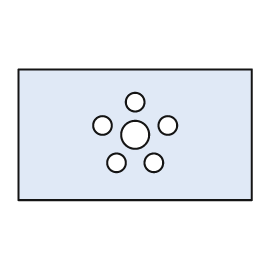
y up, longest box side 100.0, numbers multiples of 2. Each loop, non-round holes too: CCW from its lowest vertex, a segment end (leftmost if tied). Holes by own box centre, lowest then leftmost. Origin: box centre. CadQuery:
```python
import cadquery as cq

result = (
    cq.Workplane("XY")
    .moveTo(-50.0, -28.0)
    .lineTo(50.0, -28.0)
    .lineTo(50.0, 28.0)
    .lineTo(-50.0, 28.0)
    .close()
    .moveTo(-8.0, -12.0)
    .circle(4.0)
    .moveTo(8.0, -12.0)
    .circle(4.0)
    .moveTo(0.0, 0.0)
    .circle(6.0)
    .moveTo(-14.0, 4.0)
    .circle(4.0)
    .moveTo(14.0, 4.0)
    .circle(4.0)
    .moveTo(0.0, 14.0)
    .circle(4.0)
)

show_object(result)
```